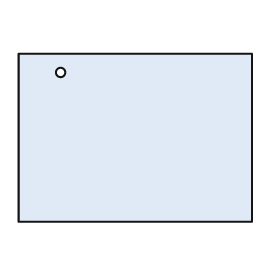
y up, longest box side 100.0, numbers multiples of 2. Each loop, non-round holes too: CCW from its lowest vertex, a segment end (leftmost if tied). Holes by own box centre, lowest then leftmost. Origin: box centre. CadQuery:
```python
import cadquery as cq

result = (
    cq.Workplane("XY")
    .moveTo(-50.0, -36.0)
    .lineTo(50.0, -36.0)
    .lineTo(50.0, 36.0)
    .lineTo(-50.0, 36.0)
    .close()
    .moveTo(-32.0, 28.0)
    .circle(2.0)
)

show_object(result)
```